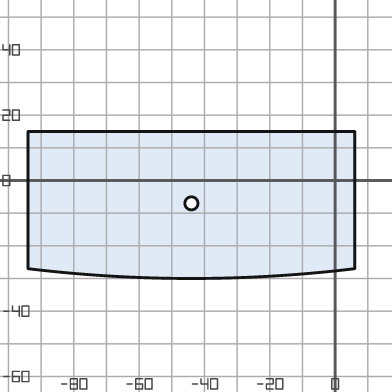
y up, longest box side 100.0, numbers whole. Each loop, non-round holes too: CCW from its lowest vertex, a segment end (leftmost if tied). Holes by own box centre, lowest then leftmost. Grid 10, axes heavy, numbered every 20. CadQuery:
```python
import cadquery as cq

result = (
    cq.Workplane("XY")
    .moveTo(-94.0, -27.0)
    .threePointArc((-44.0, -30.0), (6.0, -27.0))
    .lineTo(6.0, 15.0)
    .lineTo(-94.0, 15.0)
    .close()
    .moveTo(-44.0, -7.0)
    .circle(2.0)
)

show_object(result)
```